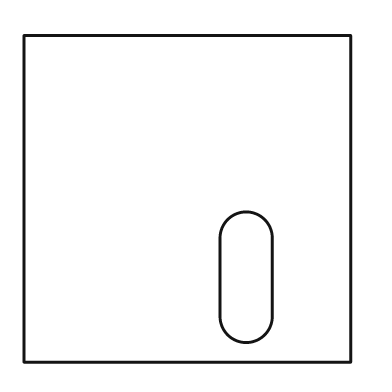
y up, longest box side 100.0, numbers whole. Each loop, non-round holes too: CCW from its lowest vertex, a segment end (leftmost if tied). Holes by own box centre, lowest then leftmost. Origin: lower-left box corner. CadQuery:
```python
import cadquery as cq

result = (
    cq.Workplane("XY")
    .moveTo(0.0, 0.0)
    .lineTo(100.0, 0.0)
    .lineTo(100.0, 100.0)
    .lineTo(0.0, 100.0)
    .close()
    .moveTo(60.0, 14.0)
    .threePointArc((68.0, 6.0), (76.0, 14.0))
    .lineTo(76.0, 38.0)
    .threePointArc((68.0, 46.0), (60.0, 38.0))
    .close()
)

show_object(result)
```